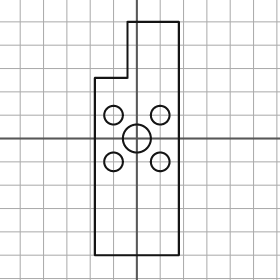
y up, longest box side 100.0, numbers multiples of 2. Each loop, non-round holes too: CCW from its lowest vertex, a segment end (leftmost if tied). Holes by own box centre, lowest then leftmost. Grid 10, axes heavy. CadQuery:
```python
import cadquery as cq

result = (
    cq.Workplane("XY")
    .moveTo(-18.0, -50.0)
    .lineTo(18.0, -50.0)
    .lineTo(18.0, 50.0)
    .lineTo(-4.0, 50.0)
    .lineTo(-4.0, 26.0)
    .lineTo(-18.0, 26.0)
    .close()
    .moveTo(-10.0, -10.0)
    .circle(4.0)
    .moveTo(10.0, -10.0)
    .circle(4.0)
    .moveTo(0.0, 0.0)
    .circle(6.0)
    .moveTo(-10.0, 10.0)
    .circle(4.0)
    .moveTo(10.0, 10.0)
    .circle(4.0)
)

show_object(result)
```